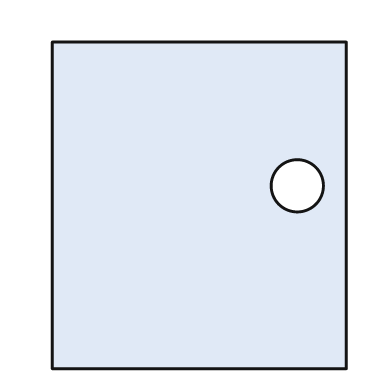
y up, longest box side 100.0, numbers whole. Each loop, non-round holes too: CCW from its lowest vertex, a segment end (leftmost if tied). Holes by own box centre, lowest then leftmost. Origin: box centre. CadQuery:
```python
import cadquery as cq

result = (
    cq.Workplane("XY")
    .moveTo(-45.0, -50.0)
    .lineTo(45.0, -50.0)
    .lineTo(45.0, 50.0)
    .lineTo(-45.0, 50.0)
    .close()
    .moveTo(30.0, 6.0)
    .circle(8.0)
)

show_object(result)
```